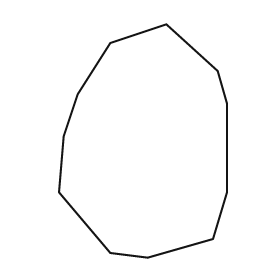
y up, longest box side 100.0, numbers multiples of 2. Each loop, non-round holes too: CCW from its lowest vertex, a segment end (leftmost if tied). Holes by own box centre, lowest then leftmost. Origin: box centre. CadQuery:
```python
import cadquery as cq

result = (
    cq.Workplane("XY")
    .moveTo(2.0, -50.0)
    .lineTo(30.0, -42.0)
    .lineTo(36.0, -22.0)
    .lineTo(36.0, 16.0)
    .lineTo(32.0, 30.0)
    .lineTo(10.0, 50.0)
    .lineTo(-14.0, 42.0)
    .lineTo(-28.0, 20.0)
    .lineTo(-34.0, 2.0)
    .lineTo(-36.0, -22.0)
    .lineTo(-14.0, -48.0)
    .close()
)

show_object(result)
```